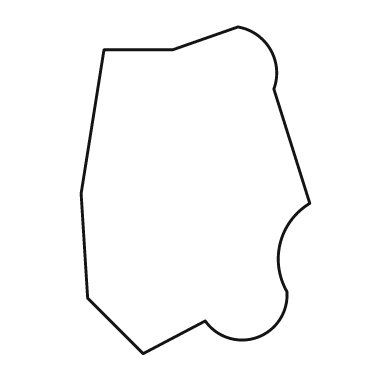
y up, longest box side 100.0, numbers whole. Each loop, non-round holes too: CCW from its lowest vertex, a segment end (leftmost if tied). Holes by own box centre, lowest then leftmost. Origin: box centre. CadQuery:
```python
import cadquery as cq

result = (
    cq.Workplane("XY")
    .moveTo(-16.0, -50.0)
    .lineTo(3.0, -40.0)
    .threePointArc((19.0, -45.0), (28.0, -31.0))
    .threePointArc((26.0, -16.0), (35.0, -4.0))
    .lineTo(24.0, 31.0)
    .threePointArc((23.0, 43.0), (13.0, 50.0))
    .lineTo(-7.0, 43.0)
    .lineTo(-28.0, 43.0)
    .lineTo(-35.0, -1.0)
    .lineTo(-33.0, -33.0)
    .close()
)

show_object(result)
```